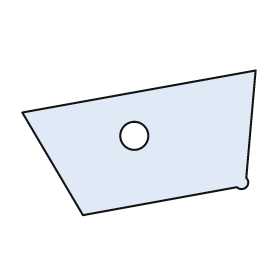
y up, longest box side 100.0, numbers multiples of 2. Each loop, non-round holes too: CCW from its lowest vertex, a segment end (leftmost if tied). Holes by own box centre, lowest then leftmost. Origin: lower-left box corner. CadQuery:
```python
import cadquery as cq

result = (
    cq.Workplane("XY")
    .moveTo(26.0, 0.0)
    .lineTo(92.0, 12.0)
    .threePointArc((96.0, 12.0), (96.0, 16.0))
    .lineTo(100.0, 62.0)
    .lineTo(0.0, 44.0)
    .close()
    .moveTo(48.0, 34.0)
    .circle(6.0)
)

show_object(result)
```